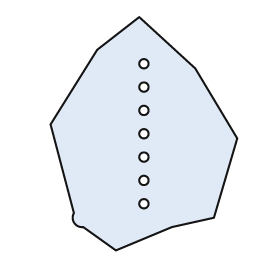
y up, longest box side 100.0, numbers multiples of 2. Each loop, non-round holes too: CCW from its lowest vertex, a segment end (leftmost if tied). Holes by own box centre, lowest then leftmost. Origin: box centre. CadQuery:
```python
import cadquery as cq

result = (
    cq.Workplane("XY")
    .moveTo(-12.0, -50.0)
    .lineTo(12.0, -40.0)
    .lineTo(30.0, -36.0)
    .lineTo(40.0, -2.0)
    .lineTo(22.0, 28.0)
    .lineTo(-2.0, 50.0)
    .lineTo(-20.0, 36.0)
    .lineTo(-40.0, 4.0)
    .lineTo(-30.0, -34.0)
    .threePointArc((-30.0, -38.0), (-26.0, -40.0))
    .close()
    .moveTo(0.0, -30.0)
    .circle(2.0)
    .moveTo(0.0, -20.0)
    .circle(2.0)
    .moveTo(0.0, -10.0)
    .circle(2.0)
    .moveTo(0.0, 0.0)
    .circle(2.0)
    .moveTo(0.0, 10.0)
    .circle(2.0)
    .moveTo(0.0, 20.0)
    .circle(2.0)
    .moveTo(0.0, 30.0)
    .circle(2.0)
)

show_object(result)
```